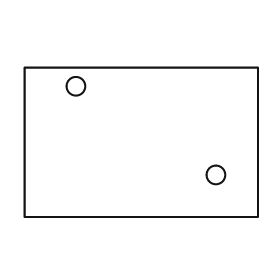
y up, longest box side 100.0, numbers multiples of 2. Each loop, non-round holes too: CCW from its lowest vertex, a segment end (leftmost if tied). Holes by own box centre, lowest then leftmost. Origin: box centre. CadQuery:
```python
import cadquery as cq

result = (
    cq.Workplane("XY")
    .moveTo(-50.0, -32.0)
    .lineTo(50.0, -32.0)
    .lineTo(50.0, 32.0)
    .lineTo(-50.0, 32.0)
    .close()
    .moveTo(32.0, -14.0)
    .circle(4.0)
    .moveTo(-28.0, 24.0)
    .circle(4.0)
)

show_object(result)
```